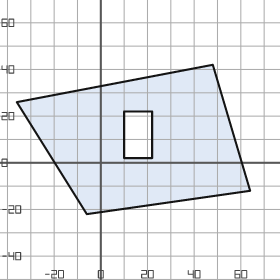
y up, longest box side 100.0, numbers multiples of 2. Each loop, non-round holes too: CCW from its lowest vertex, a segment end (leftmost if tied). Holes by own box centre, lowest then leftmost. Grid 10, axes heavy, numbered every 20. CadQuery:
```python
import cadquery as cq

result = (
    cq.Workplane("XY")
    .moveTo(-6.0, -22.0)
    .lineTo(64.0, -12.0)
    .lineTo(48.0, 42.0)
    .lineTo(-36.0, 26.0)
    .close()
    .moveTo(10.0, 2.0)
    .lineTo(22.0, 2.0)
    .lineTo(22.0, 22.0)
    .lineTo(10.0, 22.0)
    .close()
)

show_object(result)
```